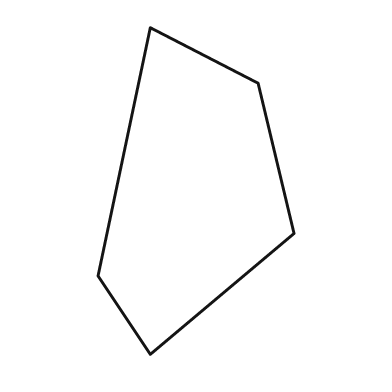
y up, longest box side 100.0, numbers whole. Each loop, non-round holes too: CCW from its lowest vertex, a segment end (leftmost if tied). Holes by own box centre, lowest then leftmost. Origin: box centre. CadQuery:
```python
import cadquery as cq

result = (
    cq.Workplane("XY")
    .moveTo(-14.0, -50.0)
    .lineTo(30.0, -13.0)
    .lineTo(19.0, 33.0)
    .lineTo(-14.0, 50.0)
    .lineTo(-30.0, -26.0)
    .close()
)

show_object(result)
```